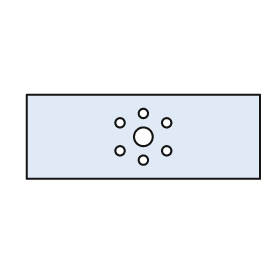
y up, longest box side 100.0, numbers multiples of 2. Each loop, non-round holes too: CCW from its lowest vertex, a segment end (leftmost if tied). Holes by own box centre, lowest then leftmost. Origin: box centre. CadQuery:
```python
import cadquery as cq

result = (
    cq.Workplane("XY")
    .moveTo(-50.0, -18.0)
    .lineTo(50.0, -18.0)
    .lineTo(50.0, 18.0)
    .lineTo(-50.0, 18.0)
    .close()
    .moveTo(0.0, -10.0)
    .circle(2.0)
    .moveTo(-10.0, -6.0)
    .circle(2.0)
    .moveTo(10.0, -6.0)
    .circle(2.0)
    .moveTo(0.0, 0.0)
    .circle(4.0)
    .moveTo(-10.0, 6.0)
    .circle(2.0)
    .moveTo(10.0, 6.0)
    .circle(2.0)
    .moveTo(0.0, 10.0)
    .circle(2.0)
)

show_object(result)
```